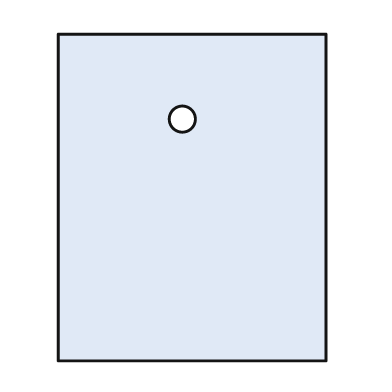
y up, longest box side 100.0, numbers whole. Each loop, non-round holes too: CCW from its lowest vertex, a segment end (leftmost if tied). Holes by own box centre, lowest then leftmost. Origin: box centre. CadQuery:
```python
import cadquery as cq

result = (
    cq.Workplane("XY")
    .moveTo(-41.0, -50.0)
    .lineTo(41.0, -50.0)
    .lineTo(41.0, 50.0)
    .lineTo(-41.0, 50.0)
    .close()
    .moveTo(-3.0, 24.0)
    .circle(4.0)
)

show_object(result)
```